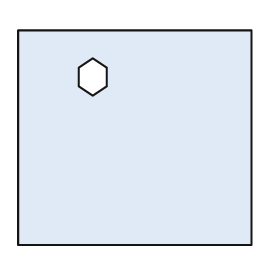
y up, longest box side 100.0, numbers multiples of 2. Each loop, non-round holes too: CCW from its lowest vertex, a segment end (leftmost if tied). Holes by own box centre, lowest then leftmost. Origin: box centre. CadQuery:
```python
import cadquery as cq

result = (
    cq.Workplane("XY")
    .moveTo(-50.0, -46.0)
    .lineTo(50.0, -46.0)
    .lineTo(50.0, 46.0)
    .lineTo(-50.0, 46.0)
    .close()
    .moveTo(-18.0, 18.0)
    .lineTo(-12.0, 22.0)
    .lineTo(-12.0, 30.0)
    .lineTo(-18.0, 34.0)
    .lineTo(-24.0, 30.0)
    .lineTo(-24.0, 22.0)
    .close()
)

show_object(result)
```